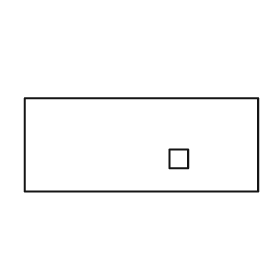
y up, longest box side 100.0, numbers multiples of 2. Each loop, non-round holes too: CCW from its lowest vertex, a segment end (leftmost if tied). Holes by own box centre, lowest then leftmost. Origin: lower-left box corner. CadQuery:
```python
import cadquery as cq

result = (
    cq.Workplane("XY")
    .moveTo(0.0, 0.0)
    .lineTo(100.0, 0.0)
    .lineTo(100.0, 40.0)
    .lineTo(0.0, 40.0)
    .close()
    .moveTo(62.0, 10.0)
    .lineTo(70.0, 10.0)
    .lineTo(70.0, 18.0)
    .lineTo(62.0, 18.0)
    .close()
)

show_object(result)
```